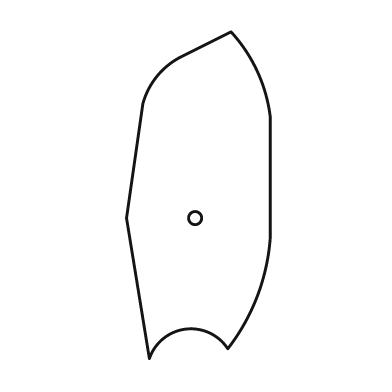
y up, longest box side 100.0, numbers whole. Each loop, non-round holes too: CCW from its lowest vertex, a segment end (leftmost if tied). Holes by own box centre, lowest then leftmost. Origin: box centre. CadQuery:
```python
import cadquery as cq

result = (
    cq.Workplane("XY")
    .moveTo(-15.0, -50.0)
    .threePointArc((-4.0, -41.0), (9.0, -47.0))
    .threePointArc((18.0, -31.0), (22.0, -13.0))
    .lineTo(22.0, 24.0)
    .threePointArc((18.0, 38.0), (10.0, 50.0))
    .lineTo(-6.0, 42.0)
    .threePointArc((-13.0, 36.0), (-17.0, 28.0))
    .lineTo(-22.0, -7.0)
    .close()
    .moveTo(-1.0, -7.0)
    .circle(2.0)
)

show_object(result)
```